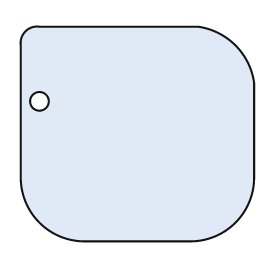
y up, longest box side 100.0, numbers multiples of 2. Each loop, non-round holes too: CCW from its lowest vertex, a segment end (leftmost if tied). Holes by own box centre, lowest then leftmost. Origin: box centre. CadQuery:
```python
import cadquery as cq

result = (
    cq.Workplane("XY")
    .moveTo(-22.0, -46.0)
    .lineTo(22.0, -46.0)
    .threePointArc((42.0, -38.0), (50.0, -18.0))
    .lineTo(50.0, 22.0)
    .threePointArc((42.0, 38.0), (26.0, 46.0))
    .lineTo(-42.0, 46.0)
    .threePointArc((-48.0, 44.0), (-50.0, 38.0))
    .lineTo(-50.0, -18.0)
    .threePointArc((-42.0, -38.0), (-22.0, -46.0))
    .close()
    .moveTo(-42.0, 14.0)
    .circle(4.0)
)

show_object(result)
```